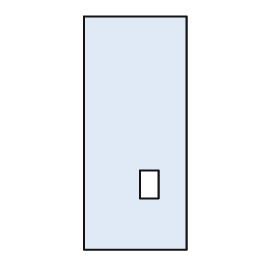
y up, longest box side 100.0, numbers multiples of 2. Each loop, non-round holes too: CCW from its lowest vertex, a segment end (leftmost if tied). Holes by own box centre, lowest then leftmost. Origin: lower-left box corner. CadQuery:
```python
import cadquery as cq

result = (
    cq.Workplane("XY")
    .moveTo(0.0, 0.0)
    .lineTo(44.0, 0.0)
    .lineTo(44.0, 100.0)
    .lineTo(0.0, 100.0)
    .close()
    .moveTo(24.0, 22.0)
    .lineTo(32.0, 22.0)
    .lineTo(32.0, 34.0)
    .lineTo(24.0, 34.0)
    .close()
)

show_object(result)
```